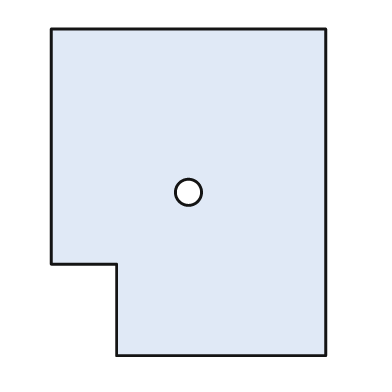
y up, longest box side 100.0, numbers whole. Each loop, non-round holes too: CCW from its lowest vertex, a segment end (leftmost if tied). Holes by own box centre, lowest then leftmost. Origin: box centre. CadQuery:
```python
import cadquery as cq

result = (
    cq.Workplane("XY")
    .moveTo(-22.0, -50.0)
    .lineTo(42.0, -50.0)
    .lineTo(42.0, 50.0)
    .lineTo(-42.0, 50.0)
    .lineTo(-42.0, -22.0)
    .lineTo(-22.0, -22.0)
    .close()
    .moveTo(0.0, 0.0)
    .circle(4.0)
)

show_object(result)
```